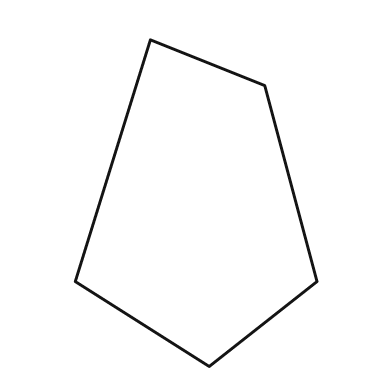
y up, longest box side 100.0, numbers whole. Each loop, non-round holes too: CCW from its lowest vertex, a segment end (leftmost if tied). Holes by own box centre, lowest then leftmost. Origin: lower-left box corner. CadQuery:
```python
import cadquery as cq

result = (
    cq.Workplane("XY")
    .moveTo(41.0, 0.0)
    .lineTo(74.0, 26.0)
    .lineTo(58.0, 86.0)
    .lineTo(23.0, 100.0)
    .lineTo(0.0, 26.0)
    .close()
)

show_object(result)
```